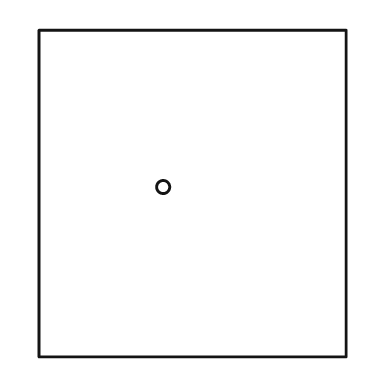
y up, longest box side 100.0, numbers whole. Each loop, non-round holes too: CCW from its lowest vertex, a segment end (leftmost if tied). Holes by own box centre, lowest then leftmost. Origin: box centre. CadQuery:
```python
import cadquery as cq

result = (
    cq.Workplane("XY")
    .moveTo(-47.0, -50.0)
    .lineTo(47.0, -50.0)
    .lineTo(47.0, 50.0)
    .lineTo(-47.0, 50.0)
    .close()
    .moveTo(-9.0, 2.0)
    .circle(2.0)
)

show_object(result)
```